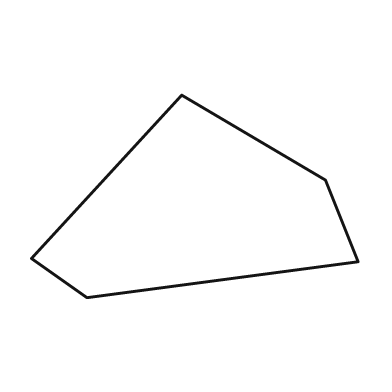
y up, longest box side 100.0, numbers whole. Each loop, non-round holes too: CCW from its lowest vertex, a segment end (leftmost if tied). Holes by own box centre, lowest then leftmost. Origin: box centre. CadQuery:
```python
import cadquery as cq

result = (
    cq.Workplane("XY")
    .moveTo(-33.0, -31.0)
    .lineTo(50.0, -20.0)
    .lineTo(40.0, 5.0)
    .lineTo(-4.0, 31.0)
    .lineTo(-50.0, -19.0)
    .close()
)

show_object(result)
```